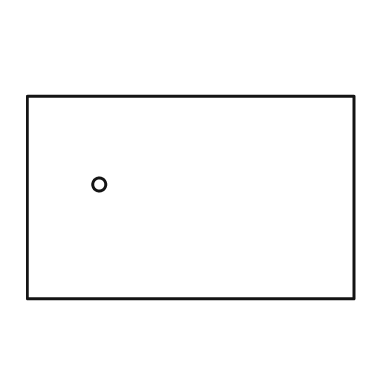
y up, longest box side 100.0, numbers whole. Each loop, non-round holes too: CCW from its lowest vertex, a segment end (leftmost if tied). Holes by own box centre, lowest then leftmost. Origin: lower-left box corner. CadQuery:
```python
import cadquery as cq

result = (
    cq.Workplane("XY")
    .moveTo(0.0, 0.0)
    .lineTo(100.0, 0.0)
    .lineTo(100.0, 62.0)
    .lineTo(0.0, 62.0)
    .close()
    .moveTo(22.0, 35.0)
    .circle(2.0)
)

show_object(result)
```